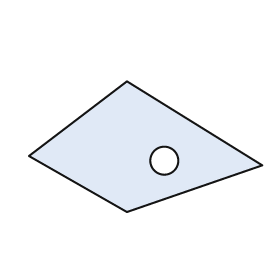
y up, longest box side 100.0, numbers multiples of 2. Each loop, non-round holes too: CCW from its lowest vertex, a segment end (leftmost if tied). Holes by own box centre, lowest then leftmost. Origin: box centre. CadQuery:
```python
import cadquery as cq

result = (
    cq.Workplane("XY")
    .moveTo(-8.0, -28.0)
    .lineTo(50.0, -8.0)
    .lineTo(-8.0, 28.0)
    .lineTo(-50.0, -4.0)
    .close()
    .moveTo(8.0, -6.0)
    .circle(6.0)
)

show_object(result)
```